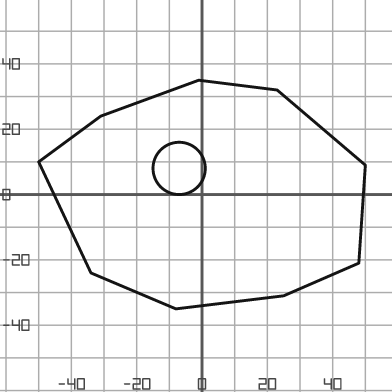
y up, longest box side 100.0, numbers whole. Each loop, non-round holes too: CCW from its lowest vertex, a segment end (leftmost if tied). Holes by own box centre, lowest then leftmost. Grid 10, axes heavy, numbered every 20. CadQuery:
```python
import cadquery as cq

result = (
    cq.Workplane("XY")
    .moveTo(-8.0, -35.0)
    .lineTo(25.0, -31.0)
    .lineTo(48.0, -21.0)
    .lineTo(50.0, 9.0)
    .lineTo(23.0, 32.0)
    .lineTo(-1.0, 35.0)
    .lineTo(-31.0, 24.0)
    .lineTo(-50.0, 10.0)
    .lineTo(-34.0, -24.0)
    .close()
    .moveTo(-7.0, 8.0)
    .circle(8.0)
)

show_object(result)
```